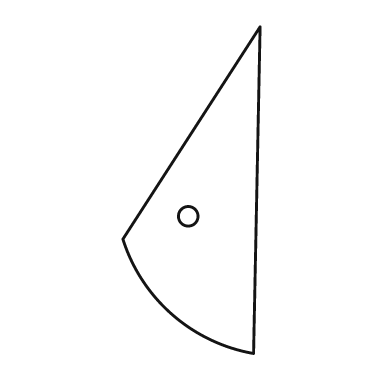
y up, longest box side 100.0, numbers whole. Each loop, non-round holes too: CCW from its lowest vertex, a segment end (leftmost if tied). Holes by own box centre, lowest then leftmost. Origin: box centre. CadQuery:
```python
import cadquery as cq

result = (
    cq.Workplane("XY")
    .moveTo(19.0, -50.0)
    .lineTo(21.0, 50.0)
    .lineTo(-21.0, -15.0)
    .threePointArc((-6.0, -38.0), (19.0, -50.0))
    .close()
    .moveTo(-1.0, -8.0)
    .circle(3.0)
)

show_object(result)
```